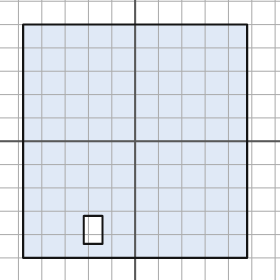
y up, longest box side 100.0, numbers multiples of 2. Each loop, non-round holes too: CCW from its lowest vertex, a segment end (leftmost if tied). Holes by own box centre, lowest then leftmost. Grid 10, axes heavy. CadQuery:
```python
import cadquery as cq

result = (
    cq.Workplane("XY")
    .moveTo(-48.0, -50.0)
    .lineTo(48.0, -50.0)
    .lineTo(48.0, 50.0)
    .lineTo(-48.0, 50.0)
    .close()
    .moveTo(-22.0, -44.0)
    .lineTo(-14.0, -44.0)
    .lineTo(-14.0, -32.0)
    .lineTo(-22.0, -32.0)
    .close()
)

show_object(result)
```